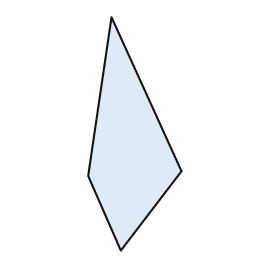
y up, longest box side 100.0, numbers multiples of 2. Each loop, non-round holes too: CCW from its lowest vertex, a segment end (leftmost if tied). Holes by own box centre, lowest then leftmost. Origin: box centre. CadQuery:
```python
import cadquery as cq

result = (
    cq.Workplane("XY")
    .moveTo(-6.0, -50.0)
    .lineTo(20.0, -16.0)
    .lineTo(-10.0, 50.0)
    .lineTo(-20.0, -18.0)
    .close()
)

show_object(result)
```